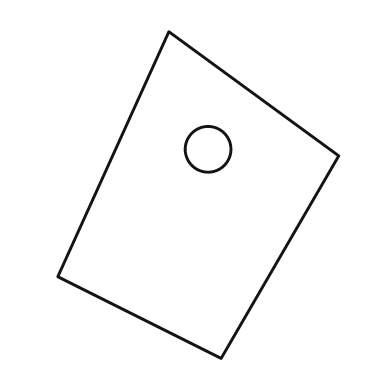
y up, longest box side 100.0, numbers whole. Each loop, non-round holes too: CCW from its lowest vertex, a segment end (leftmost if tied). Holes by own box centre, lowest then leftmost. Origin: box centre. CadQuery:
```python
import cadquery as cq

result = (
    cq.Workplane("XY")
    .moveTo(7.0, -50.0)
    .lineTo(43.0, 12.0)
    .lineTo(-9.0, 50.0)
    .lineTo(-43.0, -25.0)
    .close()
    .moveTo(3.0, 14.0)
    .circle(7.0)
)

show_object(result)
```